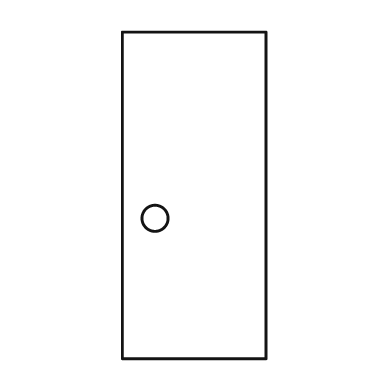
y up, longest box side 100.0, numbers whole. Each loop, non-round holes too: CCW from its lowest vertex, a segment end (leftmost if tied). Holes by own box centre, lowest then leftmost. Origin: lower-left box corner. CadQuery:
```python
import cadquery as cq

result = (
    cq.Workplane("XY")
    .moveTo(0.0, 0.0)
    .lineTo(44.0, 0.0)
    .lineTo(44.0, 100.0)
    .lineTo(0.0, 100.0)
    .close()
    .moveTo(10.0, 43.0)
    .circle(4.0)
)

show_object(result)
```